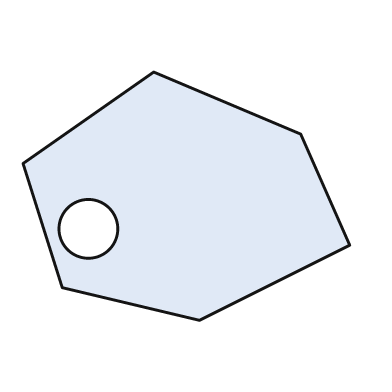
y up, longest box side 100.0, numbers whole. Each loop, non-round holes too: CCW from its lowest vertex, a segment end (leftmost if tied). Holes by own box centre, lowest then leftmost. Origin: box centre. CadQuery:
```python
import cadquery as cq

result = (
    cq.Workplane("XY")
    .moveTo(4.0, -38.0)
    .lineTo(50.0, -15.0)
    .lineTo(35.0, 19.0)
    .lineTo(-10.0, 38.0)
    .lineTo(-50.0, 10.0)
    .lineTo(-38.0, -28.0)
    .close()
    .moveTo(-30.0, -10.0)
    .circle(9.0)
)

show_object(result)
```